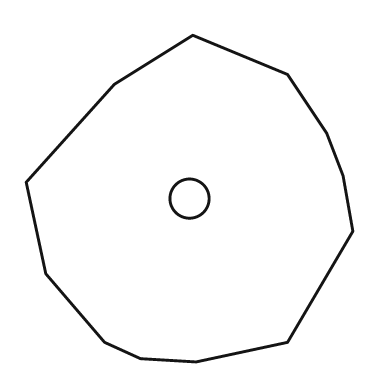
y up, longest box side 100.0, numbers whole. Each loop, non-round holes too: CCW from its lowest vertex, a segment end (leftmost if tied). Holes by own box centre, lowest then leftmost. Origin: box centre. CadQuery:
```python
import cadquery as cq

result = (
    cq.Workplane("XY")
    .moveTo(2.0, -50.0)
    .lineTo(30.0, -44.0)
    .lineTo(50.0, -10.0)
    .lineTo(47.0, 7.0)
    .lineTo(42.0, 20.0)
    .lineTo(30.0, 38.0)
    .lineTo(1.0, 50.0)
    .lineTo(-23.0, 35.0)
    .lineTo(-50.0, 5.0)
    .lineTo(-44.0, -23.0)
    .lineTo(-26.0, -44.0)
    .lineTo(-15.0, -49.0)
    .close()
    .moveTo(0.0, 0.0)
    .circle(6.0)
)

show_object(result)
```